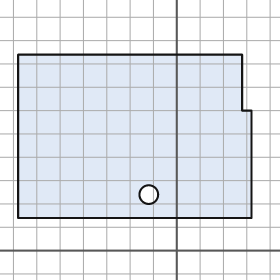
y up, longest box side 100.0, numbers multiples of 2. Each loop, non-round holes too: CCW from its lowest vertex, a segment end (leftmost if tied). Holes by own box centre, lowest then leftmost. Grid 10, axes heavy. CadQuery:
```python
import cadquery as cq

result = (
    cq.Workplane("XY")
    .moveTo(-68.0, 14.0)
    .lineTo(32.0, 14.0)
    .lineTo(32.0, 60.0)
    .lineTo(28.0, 60.0)
    .lineTo(28.0, 84.0)
    .lineTo(-68.0, 84.0)
    .close()
    .moveTo(-12.0, 24.0)
    .circle(4.0)
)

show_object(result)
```